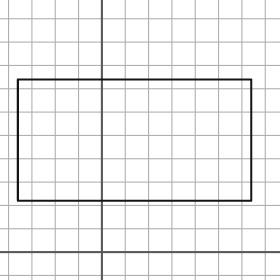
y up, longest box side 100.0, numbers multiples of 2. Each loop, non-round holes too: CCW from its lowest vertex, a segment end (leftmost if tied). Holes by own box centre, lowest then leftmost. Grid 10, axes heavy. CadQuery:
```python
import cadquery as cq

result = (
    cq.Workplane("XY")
    .moveTo(-36.0, 22.0)
    .lineTo(64.0, 22.0)
    .lineTo(64.0, 74.0)
    .lineTo(-36.0, 74.0)
    .close()
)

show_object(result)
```